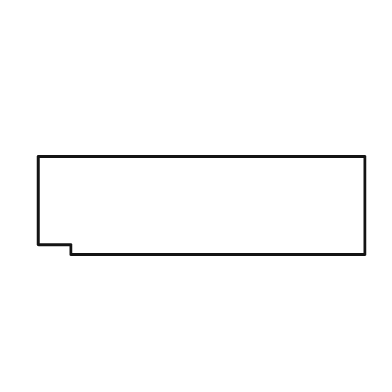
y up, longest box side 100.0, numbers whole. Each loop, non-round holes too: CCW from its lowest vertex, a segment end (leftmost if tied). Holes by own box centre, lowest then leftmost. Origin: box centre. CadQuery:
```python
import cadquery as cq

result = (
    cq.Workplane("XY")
    .moveTo(-40.0, -15.0)
    .lineTo(50.0, -15.0)
    .lineTo(50.0, 15.0)
    .lineTo(-50.0, 15.0)
    .lineTo(-50.0, -12.0)
    .lineTo(-40.0, -12.0)
    .close()
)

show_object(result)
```